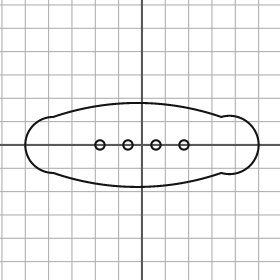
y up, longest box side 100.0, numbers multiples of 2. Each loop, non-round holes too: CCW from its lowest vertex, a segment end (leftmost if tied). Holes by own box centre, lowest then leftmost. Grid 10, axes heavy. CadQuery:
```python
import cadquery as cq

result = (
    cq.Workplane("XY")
    .moveTo(-38.0, -12.0)
    .threePointArc((-2.0, -18.0), (34.0, -12.0))
    .threePointArc((50.0, 0.0), (34.0, 12.0))
    .threePointArc((-2.0, 18.0), (-38.0, 12.0))
    .threePointArc((-50.0, 0.0), (-38.0, -12.0))
    .close()
    .moveTo(-18.0, 0.0)
    .circle(2.0)
    .moveTo(-6.0, 0.0)
    .circle(2.0)
    .moveTo(6.0, 0.0)
    .circle(2.0)
    .moveTo(18.0, 0.0)
    .circle(2.0)
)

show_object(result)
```